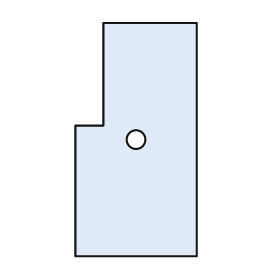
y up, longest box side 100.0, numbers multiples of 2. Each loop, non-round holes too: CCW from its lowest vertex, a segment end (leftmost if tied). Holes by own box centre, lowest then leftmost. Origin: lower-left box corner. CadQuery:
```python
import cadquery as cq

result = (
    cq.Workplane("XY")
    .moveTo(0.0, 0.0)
    .lineTo(52.0, 0.0)
    .lineTo(52.0, 100.0)
    .lineTo(12.0, 100.0)
    .lineTo(12.0, 56.0)
    .lineTo(0.0, 56.0)
    .close()
    .moveTo(26.0, 50.0)
    .circle(4.0)
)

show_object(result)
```